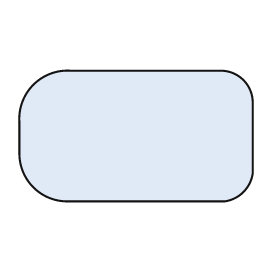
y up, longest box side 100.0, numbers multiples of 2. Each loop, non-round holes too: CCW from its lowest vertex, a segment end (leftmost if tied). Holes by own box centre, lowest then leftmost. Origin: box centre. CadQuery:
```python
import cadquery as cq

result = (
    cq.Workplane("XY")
    .moveTo(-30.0, -28.0)
    .lineTo(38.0, -28.0)
    .threePointArc((46.0, -24.0), (50.0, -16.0))
    .lineTo(50.0, 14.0)
    .threePointArc((46.0, 24.0), (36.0, 28.0))
    .lineTo(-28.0, 28.0)
    .threePointArc((-44.0, 22.0), (-50.0, 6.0))
    .lineTo(-50.0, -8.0)
    .threePointArc((-44.0, -22.0), (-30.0, -28.0))
    .close()
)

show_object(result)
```